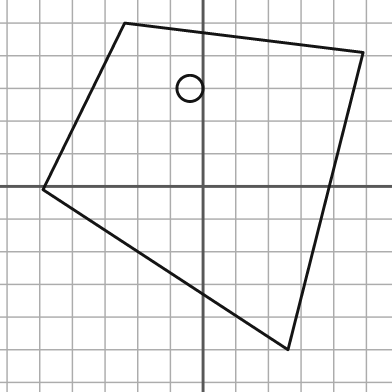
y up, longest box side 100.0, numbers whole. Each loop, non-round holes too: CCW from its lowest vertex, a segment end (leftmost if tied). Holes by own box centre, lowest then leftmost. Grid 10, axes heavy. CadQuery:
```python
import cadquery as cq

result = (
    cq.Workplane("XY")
    .moveTo(26.0, -50.0)
    .lineTo(49.0, 41.0)
    .lineTo(-24.0, 50.0)
    .lineTo(-49.0, -1.0)
    .close()
    .moveTo(-4.0, 30.0)
    .circle(4.0)
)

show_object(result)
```